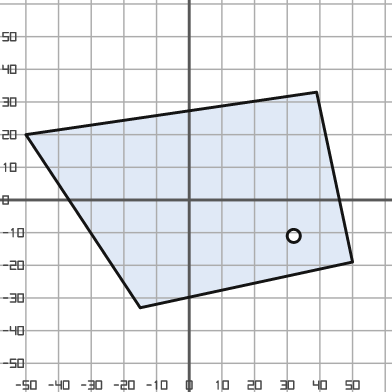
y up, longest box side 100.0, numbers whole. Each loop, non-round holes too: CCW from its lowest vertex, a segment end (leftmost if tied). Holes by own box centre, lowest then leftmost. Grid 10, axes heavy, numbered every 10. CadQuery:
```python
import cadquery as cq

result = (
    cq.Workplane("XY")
    .moveTo(-15.0, -33.0)
    .lineTo(50.0, -19.0)
    .lineTo(39.0, 33.0)
    .lineTo(-50.0, 20.0)
    .close()
    .moveTo(32.0, -11.0)
    .circle(2.0)
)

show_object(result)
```